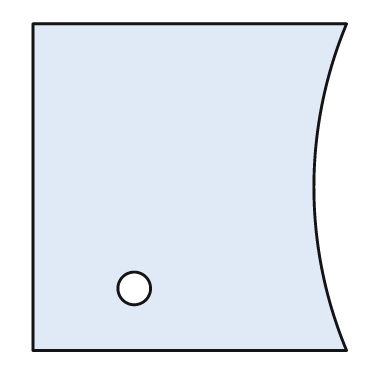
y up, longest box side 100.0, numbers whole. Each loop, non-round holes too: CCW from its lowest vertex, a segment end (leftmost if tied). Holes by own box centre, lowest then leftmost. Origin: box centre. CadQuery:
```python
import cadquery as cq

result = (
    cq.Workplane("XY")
    .moveTo(-48.0, -50.0)
    .lineTo(48.0, -50.0)
    .threePointArc((38.0, 0.0), (48.0, 50.0))
    .lineTo(-48.0, 50.0)
    .close()
    .moveTo(-17.0, -31.0)
    .circle(5.0)
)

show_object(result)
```